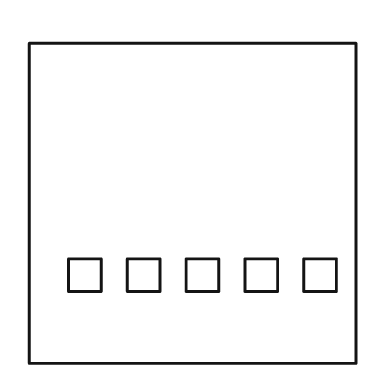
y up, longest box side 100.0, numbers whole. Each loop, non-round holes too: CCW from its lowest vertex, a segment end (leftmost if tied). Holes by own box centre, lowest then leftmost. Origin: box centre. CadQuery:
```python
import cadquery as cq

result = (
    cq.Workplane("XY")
    .moveTo(-50.0, -49.0)
    .lineTo(50.0, -49.0)
    .lineTo(50.0, 49.0)
    .lineTo(-50.0, 49.0)
    .close()
    .moveTo(-38.0, -27.0)
    .lineTo(-28.0, -27.0)
    .lineTo(-28.0, -17.0)
    .lineTo(-38.0, -17.0)
    .close()
    .moveTo(-20.0, -27.0)
    .lineTo(-10.0, -27.0)
    .lineTo(-10.0, -17.0)
    .lineTo(-20.0, -17.0)
    .close()
    .moveTo(-2.0, -27.0)
    .lineTo(8.0, -27.0)
    .lineTo(8.0, -17.0)
    .lineTo(-2.0, -17.0)
    .close()
    .moveTo(16.0, -27.0)
    .lineTo(26.0, -27.0)
    .lineTo(26.0, -17.0)
    .lineTo(16.0, -17.0)
    .close()
    .moveTo(34.0, -27.0)
    .lineTo(44.0, -27.0)
    .lineTo(44.0, -17.0)
    .lineTo(34.0, -17.0)
    .close()
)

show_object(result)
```